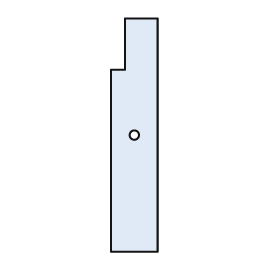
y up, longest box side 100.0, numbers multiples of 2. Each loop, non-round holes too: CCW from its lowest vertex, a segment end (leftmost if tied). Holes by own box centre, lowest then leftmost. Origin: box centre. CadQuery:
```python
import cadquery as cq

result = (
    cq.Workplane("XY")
    .moveTo(-10.0, -50.0)
    .lineTo(10.0, -50.0)
    .lineTo(10.0, 50.0)
    .lineTo(-4.0, 50.0)
    .lineTo(-4.0, 28.0)
    .lineTo(-10.0, 28.0)
    .close()
    .moveTo(0.0, 0.0)
    .circle(2.0)
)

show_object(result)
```